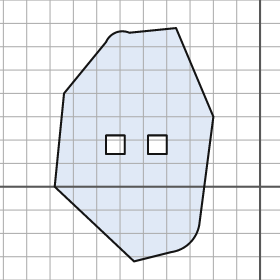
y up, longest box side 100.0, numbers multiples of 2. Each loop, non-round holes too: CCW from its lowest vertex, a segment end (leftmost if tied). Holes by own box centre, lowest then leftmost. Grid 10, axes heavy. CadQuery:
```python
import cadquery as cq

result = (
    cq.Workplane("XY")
    .moveTo(-54.0, -32.0)
    .lineTo(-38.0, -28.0)
    .threePointArc((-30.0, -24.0), (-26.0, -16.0))
    .lineTo(-20.0, 30.0)
    .lineTo(-36.0, 68.0)
    .lineTo(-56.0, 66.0)
    .threePointArc((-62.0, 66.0), (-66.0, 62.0))
    .lineTo(-84.0, 40.0)
    .lineTo(-88.0, 0.0)
    .close()
    .moveTo(-66.0, 14.0)
    .lineTo(-58.0, 14.0)
    .lineTo(-58.0, 22.0)
    .lineTo(-66.0, 22.0)
    .close()
    .moveTo(-48.0, 14.0)
    .lineTo(-40.0, 14.0)
    .lineTo(-40.0, 22.0)
    .lineTo(-48.0, 22.0)
    .close()
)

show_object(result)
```